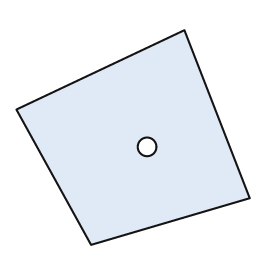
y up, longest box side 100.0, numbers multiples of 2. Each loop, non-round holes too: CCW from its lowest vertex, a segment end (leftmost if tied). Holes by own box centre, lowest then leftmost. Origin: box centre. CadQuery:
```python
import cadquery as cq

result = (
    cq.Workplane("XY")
    .moveTo(-18.0, -46.0)
    .lineTo(50.0, -26.0)
    .lineTo(22.0, 46.0)
    .lineTo(-50.0, 12.0)
    .close()
    .moveTo(6.0, -4.0)
    .circle(4.0)
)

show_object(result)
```